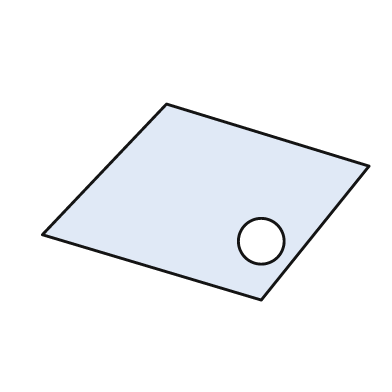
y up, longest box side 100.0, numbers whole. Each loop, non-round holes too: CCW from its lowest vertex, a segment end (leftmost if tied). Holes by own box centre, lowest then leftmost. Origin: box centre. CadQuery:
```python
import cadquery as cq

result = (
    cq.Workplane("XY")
    .moveTo(17.0, -30.0)
    .lineTo(50.0, 11.0)
    .lineTo(-12.0, 30.0)
    .lineTo(-50.0, -10.0)
    .close()
    .moveTo(17.0, -12.0)
    .circle(7.0)
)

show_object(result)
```